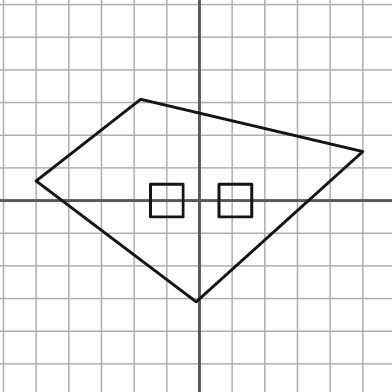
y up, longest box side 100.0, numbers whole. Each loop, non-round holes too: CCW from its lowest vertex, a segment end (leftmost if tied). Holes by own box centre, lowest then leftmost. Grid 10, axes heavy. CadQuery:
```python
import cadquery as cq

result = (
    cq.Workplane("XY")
    .moveTo(-1.0, -31.0)
    .lineTo(50.0, 15.0)
    .lineTo(-18.0, 31.0)
    .lineTo(-50.0, 6.0)
    .close()
    .moveTo(-15.0, -5.0)
    .lineTo(-5.0, -5.0)
    .lineTo(-5.0, 5.0)
    .lineTo(-15.0, 5.0)
    .close()
    .moveTo(6.0, -5.0)
    .lineTo(16.0, -5.0)
    .lineTo(16.0, 5.0)
    .lineTo(6.0, 5.0)
    .close()
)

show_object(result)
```